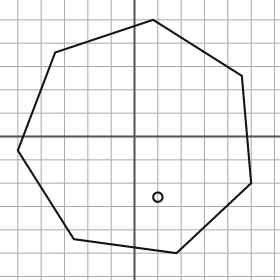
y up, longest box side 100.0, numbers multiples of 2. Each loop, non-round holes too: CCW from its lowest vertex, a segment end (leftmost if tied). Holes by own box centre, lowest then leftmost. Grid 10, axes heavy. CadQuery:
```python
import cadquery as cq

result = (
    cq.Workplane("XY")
    .moveTo(18.0, -50.0)
    .lineTo(50.0, -20.0)
    .lineTo(46.0, 26.0)
    .lineTo(8.0, 50.0)
    .lineTo(-34.0, 36.0)
    .lineTo(-50.0, -6.0)
    .lineTo(-26.0, -44.0)
    .close()
    .moveTo(10.0, -26.0)
    .circle(2.0)
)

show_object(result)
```